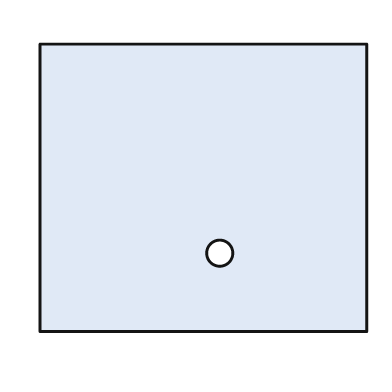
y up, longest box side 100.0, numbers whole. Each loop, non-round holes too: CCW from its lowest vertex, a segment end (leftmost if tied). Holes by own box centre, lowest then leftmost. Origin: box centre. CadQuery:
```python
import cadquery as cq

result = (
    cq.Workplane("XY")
    .moveTo(-50.0, -44.0)
    .lineTo(50.0, -44.0)
    .lineTo(50.0, 44.0)
    .lineTo(-50.0, 44.0)
    .close()
    .moveTo(5.0, -20.0)
    .circle(4.0)
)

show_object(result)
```